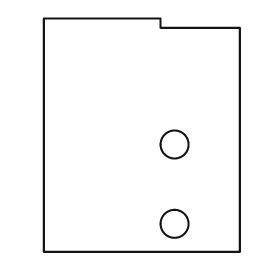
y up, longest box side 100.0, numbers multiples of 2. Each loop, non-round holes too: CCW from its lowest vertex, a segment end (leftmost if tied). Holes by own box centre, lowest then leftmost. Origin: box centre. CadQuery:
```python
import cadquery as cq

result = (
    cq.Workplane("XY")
    .moveTo(-42.0, -50.0)
    .lineTo(42.0, -50.0)
    .lineTo(42.0, 46.0)
    .lineTo(8.0, 46.0)
    .lineTo(8.0, 50.0)
    .lineTo(-42.0, 50.0)
    .close()
    .moveTo(14.0, -38.0)
    .circle(6.0)
    .moveTo(14.0, -4.0)
    .circle(6.0)
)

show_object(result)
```